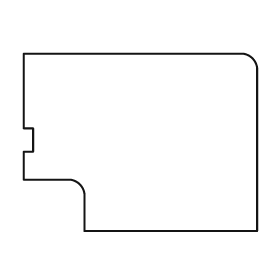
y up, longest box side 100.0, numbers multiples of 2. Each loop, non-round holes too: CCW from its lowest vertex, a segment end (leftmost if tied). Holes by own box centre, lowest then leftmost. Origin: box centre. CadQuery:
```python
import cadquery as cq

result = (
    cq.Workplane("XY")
    .moveTo(-24.0, -38.0)
    .lineTo(50.0, -38.0)
    .lineTo(50.0, 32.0)
    .threePointArc((48.0, 36.0), (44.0, 38.0))
    .lineTo(-50.0, 38.0)
    .lineTo(-50.0, 6.0)
    .lineTo(-46.0, 6.0)
    .lineTo(-46.0, -4.0)
    .lineTo(-50.0, -4.0)
    .lineTo(-50.0, -16.0)
    .lineTo(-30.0, -16.0)
    .threePointArc((-26.0, -18.0), (-24.0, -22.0))
    .close()
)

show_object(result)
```